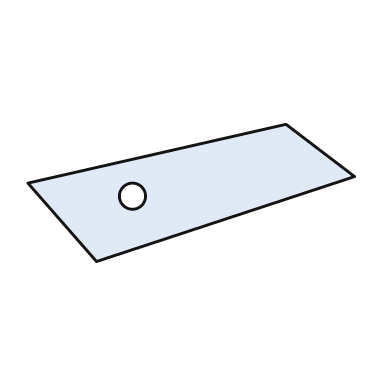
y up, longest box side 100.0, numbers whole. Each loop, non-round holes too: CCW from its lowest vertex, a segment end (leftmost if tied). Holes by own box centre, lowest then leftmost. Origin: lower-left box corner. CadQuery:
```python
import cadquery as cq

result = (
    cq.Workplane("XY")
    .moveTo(21.0, 0.0)
    .lineTo(100.0, 26.0)
    .lineTo(79.0, 42.0)
    .lineTo(0.0, 24.0)
    .close()
    .moveTo(32.0, 20.0)
    .circle(4.0)
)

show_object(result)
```